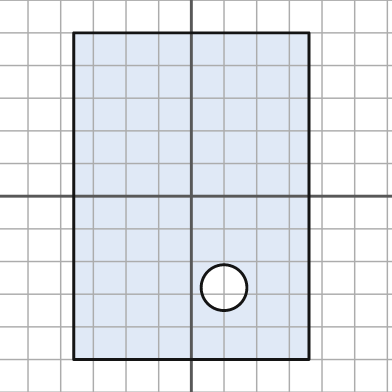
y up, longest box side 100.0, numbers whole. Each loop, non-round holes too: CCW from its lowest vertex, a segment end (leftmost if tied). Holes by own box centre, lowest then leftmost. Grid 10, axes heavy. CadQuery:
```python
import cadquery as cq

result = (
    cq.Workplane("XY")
    .moveTo(-36.0, -50.0)
    .lineTo(36.0, -50.0)
    .lineTo(36.0, 50.0)
    .lineTo(-36.0, 50.0)
    .close()
    .moveTo(10.0, -28.0)
    .circle(7.0)
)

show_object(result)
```